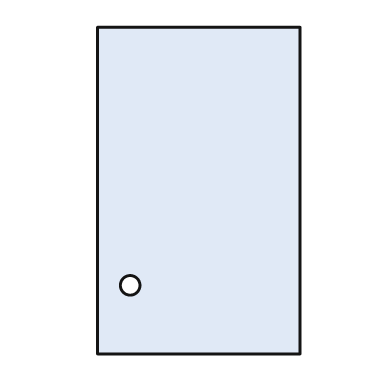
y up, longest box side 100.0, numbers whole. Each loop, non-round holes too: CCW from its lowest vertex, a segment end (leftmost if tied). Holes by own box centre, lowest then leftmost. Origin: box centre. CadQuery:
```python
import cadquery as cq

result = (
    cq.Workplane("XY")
    .moveTo(-31.0, -50.0)
    .lineTo(31.0, -50.0)
    .lineTo(31.0, 50.0)
    .lineTo(-31.0, 50.0)
    .close()
    .moveTo(-21.0, -29.0)
    .circle(3.0)
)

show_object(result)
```